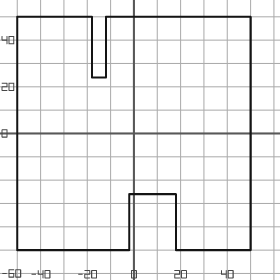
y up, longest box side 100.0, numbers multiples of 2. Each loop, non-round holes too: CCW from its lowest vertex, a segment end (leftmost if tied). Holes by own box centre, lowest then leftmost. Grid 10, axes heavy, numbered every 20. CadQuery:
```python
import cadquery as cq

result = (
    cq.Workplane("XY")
    .moveTo(-50.0, -50.0)
    .lineTo(-2.0, -50.0)
    .lineTo(-2.0, -26.0)
    .lineTo(18.0, -26.0)
    .lineTo(18.0, -50.0)
    .lineTo(50.0, -50.0)
    .lineTo(50.0, 50.0)
    .lineTo(-12.0, 50.0)
    .lineTo(-12.0, 24.0)
    .lineTo(-18.0, 24.0)
    .lineTo(-18.0, 50.0)
    .lineTo(-50.0, 50.0)
    .close()
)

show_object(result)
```